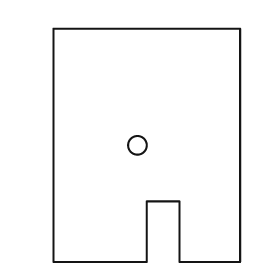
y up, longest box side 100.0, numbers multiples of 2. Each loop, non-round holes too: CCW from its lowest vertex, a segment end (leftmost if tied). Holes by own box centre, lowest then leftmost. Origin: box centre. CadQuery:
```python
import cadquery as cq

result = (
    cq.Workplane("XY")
    .moveTo(-40.0, -50.0)
    .lineTo(0.0, -50.0)
    .lineTo(0.0, -24.0)
    .lineTo(14.0, -24.0)
    .lineTo(14.0, -50.0)
    .lineTo(40.0, -50.0)
    .lineTo(40.0, 50.0)
    .lineTo(-40.0, 50.0)
    .close()
    .moveTo(-4.0, 0.0)
    .circle(4.0)
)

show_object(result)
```